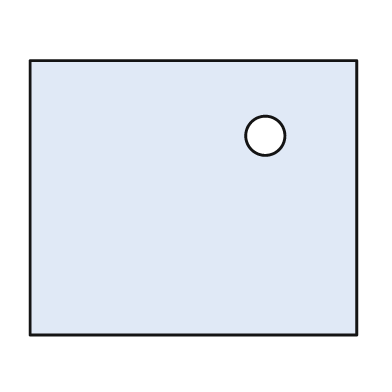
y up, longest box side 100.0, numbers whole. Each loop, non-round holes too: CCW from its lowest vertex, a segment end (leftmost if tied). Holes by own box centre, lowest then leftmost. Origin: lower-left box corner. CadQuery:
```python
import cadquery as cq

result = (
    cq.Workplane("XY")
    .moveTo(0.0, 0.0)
    .lineTo(100.0, 0.0)
    .lineTo(100.0, 84.0)
    .lineTo(0.0, 84.0)
    .close()
    .moveTo(72.0, 61.0)
    .circle(6.0)
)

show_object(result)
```